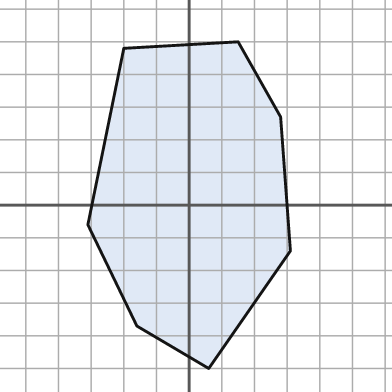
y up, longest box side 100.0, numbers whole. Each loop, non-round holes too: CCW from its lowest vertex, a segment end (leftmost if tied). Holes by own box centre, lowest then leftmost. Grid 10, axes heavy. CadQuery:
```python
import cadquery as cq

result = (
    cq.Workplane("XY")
    .moveTo(6.0, -50.0)
    .lineTo(31.0, -14.0)
    .lineTo(28.0, 27.0)
    .lineTo(15.0, 50.0)
    .lineTo(-20.0, 48.0)
    .lineTo(-31.0, -6.0)
    .lineTo(-16.0, -37.0)
    .close()
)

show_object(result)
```